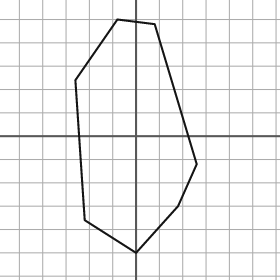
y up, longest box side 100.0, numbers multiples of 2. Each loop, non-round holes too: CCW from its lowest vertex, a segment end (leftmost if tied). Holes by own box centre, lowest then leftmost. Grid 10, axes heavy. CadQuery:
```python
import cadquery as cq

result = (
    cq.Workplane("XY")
    .moveTo(0.0, -50.0)
    .lineTo(18.0, -30.0)
    .lineTo(26.0, -12.0)
    .lineTo(8.0, 48.0)
    .lineTo(-8.0, 50.0)
    .lineTo(-26.0, 24.0)
    .lineTo(-22.0, -36.0)
    .close()
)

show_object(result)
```